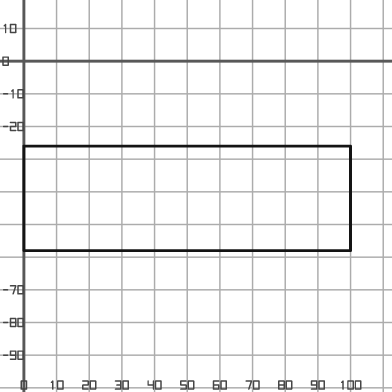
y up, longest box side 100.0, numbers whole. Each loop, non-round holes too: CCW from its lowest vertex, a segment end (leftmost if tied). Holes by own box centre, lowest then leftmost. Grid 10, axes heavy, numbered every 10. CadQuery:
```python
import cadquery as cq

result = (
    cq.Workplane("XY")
    .moveTo(0.0, -58.0)
    .lineTo(100.0, -58.0)
    .lineTo(100.0, -26.0)
    .lineTo(0.0, -26.0)
    .close()
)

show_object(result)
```